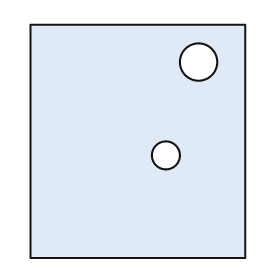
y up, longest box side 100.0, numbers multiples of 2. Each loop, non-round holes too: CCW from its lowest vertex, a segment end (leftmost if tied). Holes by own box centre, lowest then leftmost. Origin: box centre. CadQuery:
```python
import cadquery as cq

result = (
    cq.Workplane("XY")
    .moveTo(-46.0, -50.0)
    .lineTo(46.0, -50.0)
    .lineTo(46.0, 50.0)
    .lineTo(-46.0, 50.0)
    .close()
    .moveTo(12.0, -6.0)
    .circle(6.0)
    .moveTo(26.0, 34.0)
    .circle(8.0)
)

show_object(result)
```